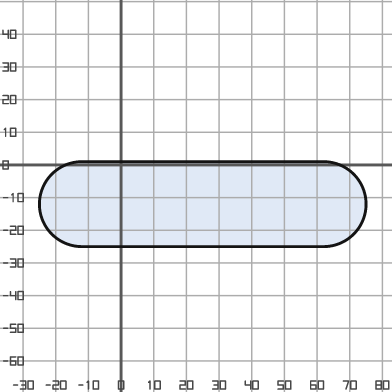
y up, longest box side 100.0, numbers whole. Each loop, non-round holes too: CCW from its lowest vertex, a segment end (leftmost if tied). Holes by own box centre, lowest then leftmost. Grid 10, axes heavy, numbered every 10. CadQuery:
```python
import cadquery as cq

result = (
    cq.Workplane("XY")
    .moveTo(-12.0, -25.0)
    .lineTo(62.0, -25.0)
    .threePointArc((75.0, -12.0), (62.0, 1.0))
    .lineTo(-12.0, 1.0)
    .threePointArc((-25.0, -12.0), (-12.0, -25.0))
    .close()
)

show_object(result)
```